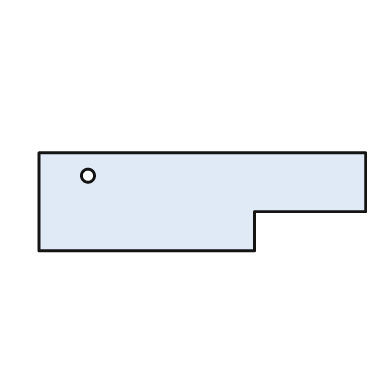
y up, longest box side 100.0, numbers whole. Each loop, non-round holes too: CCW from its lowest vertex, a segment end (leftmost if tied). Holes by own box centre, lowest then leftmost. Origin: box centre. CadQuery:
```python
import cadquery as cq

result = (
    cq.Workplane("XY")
    .moveTo(-50.0, -15.0)
    .lineTo(16.0, -15.0)
    .lineTo(16.0, -3.0)
    .lineTo(50.0, -3.0)
    .lineTo(50.0, 15.0)
    .lineTo(-50.0, 15.0)
    .close()
    .moveTo(-35.0, 8.0)
    .circle(2.0)
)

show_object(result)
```